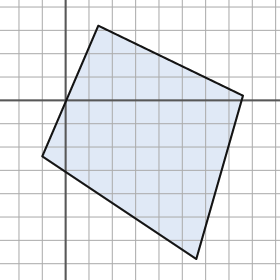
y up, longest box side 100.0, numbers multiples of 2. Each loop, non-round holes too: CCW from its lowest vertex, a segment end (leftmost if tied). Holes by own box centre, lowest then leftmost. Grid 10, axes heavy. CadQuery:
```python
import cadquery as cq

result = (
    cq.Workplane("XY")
    .moveTo(56.0, -68.0)
    .lineTo(76.0, 2.0)
    .lineTo(14.0, 32.0)
    .lineTo(-10.0, -24.0)
    .close()
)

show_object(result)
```